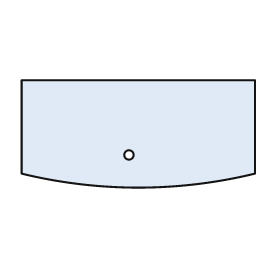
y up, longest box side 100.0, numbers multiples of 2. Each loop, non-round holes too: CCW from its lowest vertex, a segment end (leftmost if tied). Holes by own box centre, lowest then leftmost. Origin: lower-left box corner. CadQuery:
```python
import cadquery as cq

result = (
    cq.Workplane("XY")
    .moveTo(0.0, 6.0)
    .threePointArc((50.0, 0.0), (100.0, 6.0))
    .lineTo(100.0, 46.0)
    .lineTo(0.0, 46.0)
    .close()
    .moveTo(46.0, 14.0)
    .circle(2.0)
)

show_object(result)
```